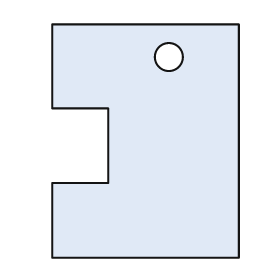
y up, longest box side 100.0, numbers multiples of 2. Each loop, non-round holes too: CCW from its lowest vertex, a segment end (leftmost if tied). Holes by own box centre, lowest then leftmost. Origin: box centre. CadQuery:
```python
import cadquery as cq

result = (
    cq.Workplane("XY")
    .moveTo(-40.0, -50.0)
    .lineTo(40.0, -50.0)
    .lineTo(40.0, 50.0)
    .lineTo(-40.0, 50.0)
    .lineTo(-40.0, 14.0)
    .lineTo(-16.0, 14.0)
    .lineTo(-16.0, -18.0)
    .lineTo(-40.0, -18.0)
    .close()
    .moveTo(10.0, 36.0)
    .circle(6.0)
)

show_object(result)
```